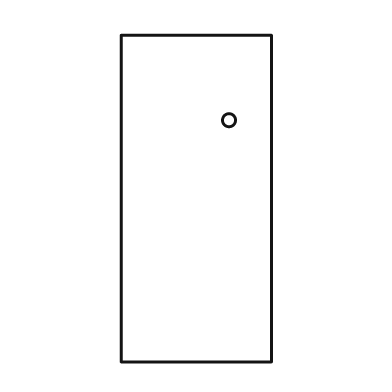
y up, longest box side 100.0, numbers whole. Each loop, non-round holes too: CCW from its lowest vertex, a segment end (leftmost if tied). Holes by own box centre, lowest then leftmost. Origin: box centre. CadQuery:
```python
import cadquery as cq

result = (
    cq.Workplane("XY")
    .moveTo(-23.0, -50.0)
    .lineTo(23.0, -50.0)
    .lineTo(23.0, 50.0)
    .lineTo(-23.0, 50.0)
    .close()
    .moveTo(10.0, 24.0)
    .circle(2.0)
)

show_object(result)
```